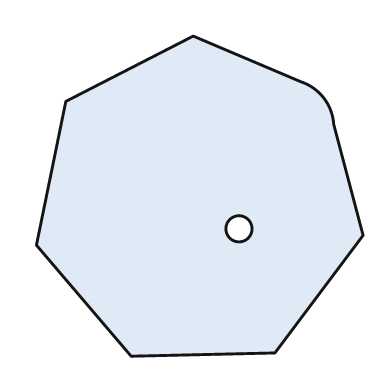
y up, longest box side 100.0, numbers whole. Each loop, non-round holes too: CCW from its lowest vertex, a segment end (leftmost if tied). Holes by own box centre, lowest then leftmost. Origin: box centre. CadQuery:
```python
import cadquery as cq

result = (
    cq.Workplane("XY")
    .moveTo(-21.0, -49.0)
    .lineTo(23.0, -48.0)
    .lineTo(50.0, -12.0)
    .lineTo(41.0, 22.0)
    .threePointArc((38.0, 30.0), (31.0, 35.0))
    .lineTo(-2.0, 49.0)
    .lineTo(-41.0, 29.0)
    .lineTo(-50.0, -15.0)
    .close()
    .moveTo(12.0, -10.0)
    .circle(4.0)
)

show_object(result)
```